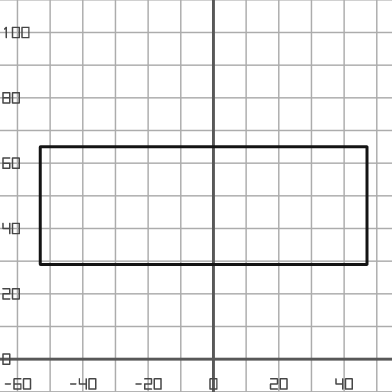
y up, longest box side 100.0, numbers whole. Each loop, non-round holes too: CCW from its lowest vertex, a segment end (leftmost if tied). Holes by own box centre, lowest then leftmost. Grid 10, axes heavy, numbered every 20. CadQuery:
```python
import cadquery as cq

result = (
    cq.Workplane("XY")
    .moveTo(-53.0, 29.0)
    .lineTo(47.0, 29.0)
    .lineTo(47.0, 65.0)
    .lineTo(-53.0, 65.0)
    .close()
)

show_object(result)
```